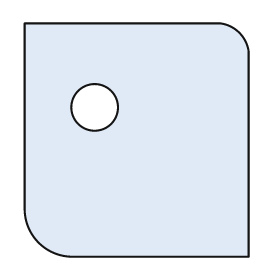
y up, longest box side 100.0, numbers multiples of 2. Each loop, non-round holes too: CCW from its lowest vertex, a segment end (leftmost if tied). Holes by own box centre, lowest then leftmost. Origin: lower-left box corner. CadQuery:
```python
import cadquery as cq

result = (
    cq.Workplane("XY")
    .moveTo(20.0, 0.0)
    .lineTo(96.0, 0.0)
    .lineTo(96.0, 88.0)
    .threePointArc((92.0, 96.0), (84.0, 100.0))
    .lineTo(0.0, 100.0)
    .lineTo(0.0, 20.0)
    .threePointArc((6.0, 6.0), (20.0, 0.0))
    .close()
    .moveTo(30.0, 64.0)
    .circle(10.0)
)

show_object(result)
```